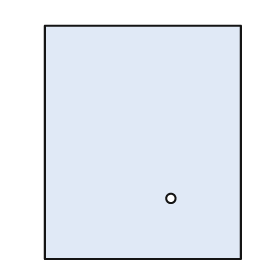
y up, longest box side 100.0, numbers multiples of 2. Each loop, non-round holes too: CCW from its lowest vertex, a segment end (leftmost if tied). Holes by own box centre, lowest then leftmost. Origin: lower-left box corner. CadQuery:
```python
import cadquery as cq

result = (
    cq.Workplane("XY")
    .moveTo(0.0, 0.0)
    .lineTo(84.0, 0.0)
    .lineTo(84.0, 100.0)
    .lineTo(0.0, 100.0)
    .close()
    .moveTo(54.0, 26.0)
    .circle(2.0)
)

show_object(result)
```